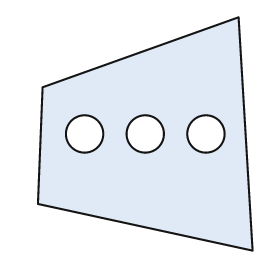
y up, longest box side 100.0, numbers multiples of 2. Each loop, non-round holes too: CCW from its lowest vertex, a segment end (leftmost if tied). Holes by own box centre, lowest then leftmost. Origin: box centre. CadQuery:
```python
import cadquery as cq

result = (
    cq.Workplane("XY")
    .moveTo(46.0, -50.0)
    .lineTo(40.0, 50.0)
    .lineTo(-44.0, 20.0)
    .lineTo(-46.0, -30.0)
    .close()
    .moveTo(-26.0, 0.0)
    .circle(8.0)
    .moveTo(0.0, 0.0)
    .circle(8.0)
    .moveTo(26.0, 0.0)
    .circle(8.0)
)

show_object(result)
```